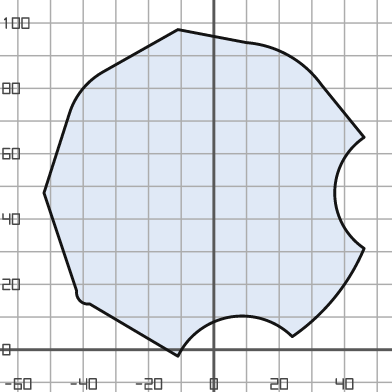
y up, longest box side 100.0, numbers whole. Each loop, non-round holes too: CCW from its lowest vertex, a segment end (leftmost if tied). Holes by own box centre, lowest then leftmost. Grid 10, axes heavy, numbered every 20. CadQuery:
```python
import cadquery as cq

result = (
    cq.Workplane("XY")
    .moveTo(-11.0, -2.0)
    .threePointArc((5.0, 10.0), (24.0, 4.0))
    .threePointArc((37.0, 16.0), (46.0, 31.0))
    .threePointArc((37.0, 48.0), (46.0, 65.0))
    .lineTo(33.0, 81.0)
    .threePointArc((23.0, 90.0), (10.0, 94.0))
    .lineTo(-11.0, 98.0)
    .lineTo(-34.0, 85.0)
    .threePointArc((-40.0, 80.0), (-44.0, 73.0))
    .lineTo(-52.0, 48.0)
    .lineTo(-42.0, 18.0)
    .threePointArc((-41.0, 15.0), (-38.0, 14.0))
    .close()
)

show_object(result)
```